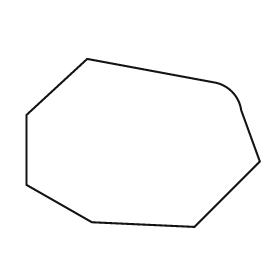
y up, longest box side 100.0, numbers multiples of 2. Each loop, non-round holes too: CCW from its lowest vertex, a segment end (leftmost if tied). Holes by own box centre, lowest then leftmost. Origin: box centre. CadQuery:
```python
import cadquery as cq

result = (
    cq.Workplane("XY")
    .moveTo(22.0, -36.0)
    .lineTo(50.0, -8.0)
    .lineTo(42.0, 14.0)
    .threePointArc((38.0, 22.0), (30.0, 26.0))
    .lineTo(-24.0, 36.0)
    .lineTo(-50.0, 12.0)
    .lineTo(-50.0, -18.0)
    .lineTo(-22.0, -34.0)
    .close()
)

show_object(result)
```